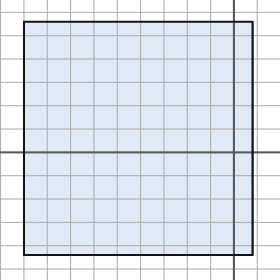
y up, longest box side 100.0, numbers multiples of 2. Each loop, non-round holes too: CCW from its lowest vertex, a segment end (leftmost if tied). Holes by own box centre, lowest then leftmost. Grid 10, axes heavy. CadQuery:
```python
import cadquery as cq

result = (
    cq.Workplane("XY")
    .moveTo(-90.0, -44.0)
    .lineTo(8.0, -44.0)
    .lineTo(8.0, 56.0)
    .lineTo(-90.0, 56.0)
    .close()
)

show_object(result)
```